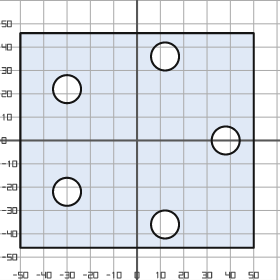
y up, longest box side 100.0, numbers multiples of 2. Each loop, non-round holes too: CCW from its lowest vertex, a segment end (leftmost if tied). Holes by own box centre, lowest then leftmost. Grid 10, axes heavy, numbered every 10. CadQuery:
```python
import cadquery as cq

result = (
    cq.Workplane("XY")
    .moveTo(-50.0, -46.0)
    .lineTo(50.0, -46.0)
    .lineTo(50.0, 46.0)
    .lineTo(-50.0, 46.0)
    .close()
    .moveTo(12.0, -36.0)
    .circle(6.0)
    .moveTo(-30.0, -22.0)
    .circle(6.0)
    .moveTo(38.0, 0.0)
    .circle(6.0)
    .moveTo(-30.0, 22.0)
    .circle(6.0)
    .moveTo(12.0, 36.0)
    .circle(6.0)
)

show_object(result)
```